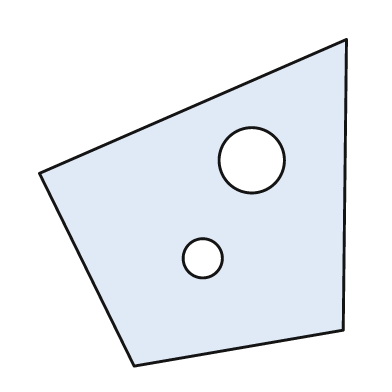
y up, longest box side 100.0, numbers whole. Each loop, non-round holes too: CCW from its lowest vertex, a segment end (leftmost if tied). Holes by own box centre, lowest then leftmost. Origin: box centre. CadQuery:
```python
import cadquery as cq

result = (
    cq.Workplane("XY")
    .moveTo(-18.0, -50.0)
    .lineTo(46.0, -39.0)
    .lineTo(47.0, 50.0)
    .lineTo(-47.0, 9.0)
    .close()
    .moveTo(3.0, -17.0)
    .circle(6.0)
    .moveTo(18.0, 13.0)
    .circle(10.0)
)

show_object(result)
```